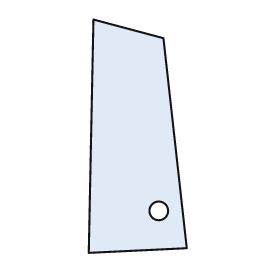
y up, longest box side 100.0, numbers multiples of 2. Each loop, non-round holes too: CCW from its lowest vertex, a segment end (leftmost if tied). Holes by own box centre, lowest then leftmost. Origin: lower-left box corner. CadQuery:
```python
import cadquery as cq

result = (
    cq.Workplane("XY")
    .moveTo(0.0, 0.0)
    .lineTo(42.0, 2.0)
    .lineTo(32.0, 92.0)
    .lineTo(2.0, 100.0)
    .close()
    .moveTo(30.0, 18.0)
    .circle(4.0)
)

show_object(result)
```